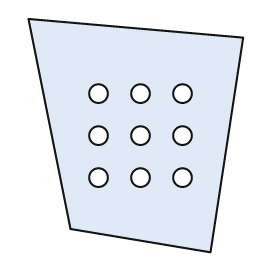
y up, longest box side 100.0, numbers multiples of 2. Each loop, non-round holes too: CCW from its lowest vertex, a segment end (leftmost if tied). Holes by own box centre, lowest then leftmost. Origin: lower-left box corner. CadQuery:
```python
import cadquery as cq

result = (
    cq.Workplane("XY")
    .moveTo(78.0, 0.0)
    .lineTo(92.0, 92.0)
    .lineTo(0.0, 100.0)
    .lineTo(18.0, 10.0)
    .close()
    .moveTo(30.0, 32.0)
    .circle(4.0)
    .moveTo(48.0, 32.0)
    .circle(4.0)
    .moveTo(66.0, 32.0)
    .circle(4.0)
    .moveTo(30.0, 50.0)
    .circle(4.0)
    .moveTo(48.0, 50.0)
    .circle(4.0)
    .moveTo(66.0, 50.0)
    .circle(4.0)
    .moveTo(30.0, 68.0)
    .circle(4.0)
    .moveTo(48.0, 68.0)
    .circle(4.0)
    .moveTo(66.0, 68.0)
    .circle(4.0)
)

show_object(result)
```